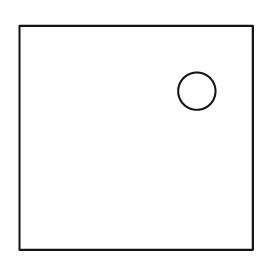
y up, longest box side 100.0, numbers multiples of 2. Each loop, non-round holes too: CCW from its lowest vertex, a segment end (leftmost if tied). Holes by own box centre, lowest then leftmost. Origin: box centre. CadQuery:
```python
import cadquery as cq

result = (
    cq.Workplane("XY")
    .moveTo(-50.0, -48.0)
    .lineTo(50.0, -48.0)
    .lineTo(50.0, 48.0)
    .lineTo(-50.0, 48.0)
    .close()
    .moveTo(26.0, 20.0)
    .circle(8.0)
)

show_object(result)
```